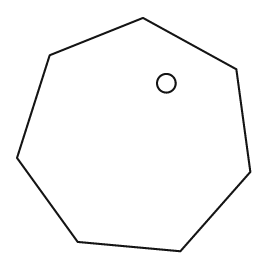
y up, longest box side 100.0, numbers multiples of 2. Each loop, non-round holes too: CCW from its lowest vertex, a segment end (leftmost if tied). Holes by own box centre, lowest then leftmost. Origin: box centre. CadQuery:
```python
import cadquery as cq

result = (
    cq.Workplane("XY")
    .moveTo(20.0, -50.0)
    .lineTo(50.0, -16.0)
    .lineTo(44.0, 28.0)
    .lineTo(4.0, 50.0)
    .lineTo(-36.0, 34.0)
    .lineTo(-50.0, -10.0)
    .lineTo(-24.0, -46.0)
    .close()
    .moveTo(14.0, 22.0)
    .circle(4.0)
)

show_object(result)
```